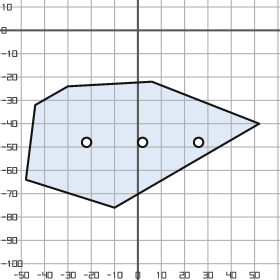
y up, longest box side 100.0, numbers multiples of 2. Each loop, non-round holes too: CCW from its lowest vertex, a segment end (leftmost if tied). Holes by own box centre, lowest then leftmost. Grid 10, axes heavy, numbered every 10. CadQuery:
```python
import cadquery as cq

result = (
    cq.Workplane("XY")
    .moveTo(-10.0, -76.0)
    .lineTo(52.0, -40.0)
    .lineTo(6.0, -22.0)
    .lineTo(-30.0, -24.0)
    .lineTo(-44.0, -32.0)
    .lineTo(-48.0, -64.0)
    .close()
    .moveTo(-22.0, -48.0)
    .circle(2.0)
    .moveTo(2.0, -48.0)
    .circle(2.0)
    .moveTo(26.0, -48.0)
    .circle(2.0)
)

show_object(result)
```